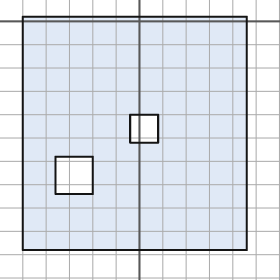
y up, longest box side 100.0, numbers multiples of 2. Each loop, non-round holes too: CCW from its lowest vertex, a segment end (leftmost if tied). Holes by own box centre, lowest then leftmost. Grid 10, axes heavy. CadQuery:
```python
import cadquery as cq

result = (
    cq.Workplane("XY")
    .moveTo(-50.0, -98.0)
    .lineTo(46.0, -98.0)
    .lineTo(46.0, 2.0)
    .lineTo(-50.0, 2.0)
    .close()
    .moveTo(-36.0, -74.0)
    .lineTo(-20.0, -74.0)
    .lineTo(-20.0, -58.0)
    .lineTo(-36.0, -58.0)
    .close()
    .moveTo(-4.0, -52.0)
    .lineTo(8.0, -52.0)
    .lineTo(8.0, -40.0)
    .lineTo(-4.0, -40.0)
    .close()
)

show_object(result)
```